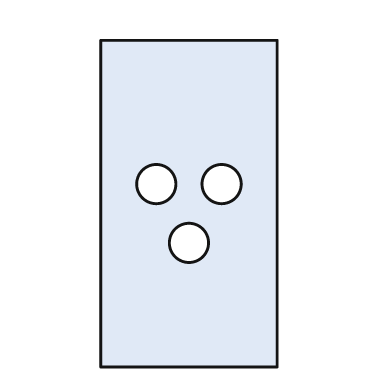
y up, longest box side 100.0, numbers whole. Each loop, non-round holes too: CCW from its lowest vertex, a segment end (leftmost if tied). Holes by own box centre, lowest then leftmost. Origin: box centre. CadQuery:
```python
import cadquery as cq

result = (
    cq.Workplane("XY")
    .moveTo(-27.0, -50.0)
    .lineTo(27.0, -50.0)
    .lineTo(27.0, 50.0)
    .lineTo(-27.0, 50.0)
    .close()
    .moveTo(0.0, -12.0)
    .circle(6.0)
    .moveTo(-10.0, 6.0)
    .circle(6.0)
    .moveTo(10.0, 6.0)
    .circle(6.0)
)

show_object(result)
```